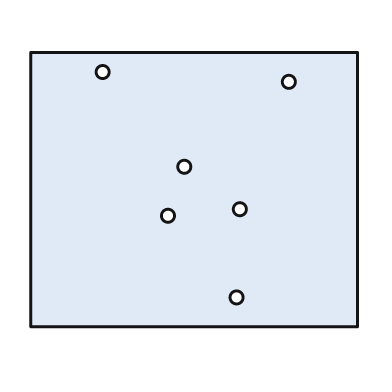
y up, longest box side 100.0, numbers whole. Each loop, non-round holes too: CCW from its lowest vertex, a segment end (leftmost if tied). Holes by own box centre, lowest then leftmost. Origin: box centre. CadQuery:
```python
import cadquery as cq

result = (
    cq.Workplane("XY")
    .moveTo(-50.0, -42.0)
    .lineTo(50.0, -42.0)
    .lineTo(50.0, 42.0)
    .lineTo(-50.0, 42.0)
    .close()
    .moveTo(13.0, -33.0)
    .circle(2.0)
    .moveTo(-8.0, -8.0)
    .circle(2.0)
    .moveTo(14.0, -6.0)
    .circle(2.0)
    .moveTo(-3.0, 7.0)
    .circle(2.0)
    .moveTo(29.0, 33.0)
    .circle(2.0)
    .moveTo(-28.0, 36.0)
    .circle(2.0)
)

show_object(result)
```